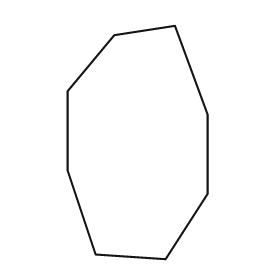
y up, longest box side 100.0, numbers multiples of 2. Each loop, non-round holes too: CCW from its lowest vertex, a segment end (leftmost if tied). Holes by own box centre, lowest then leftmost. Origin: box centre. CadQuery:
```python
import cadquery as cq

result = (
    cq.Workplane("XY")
    .moveTo(12.0, -50.0)
    .lineTo(30.0, -22.0)
    .lineTo(30.0, 12.0)
    .lineTo(16.0, 50.0)
    .lineTo(-10.0, 46.0)
    .lineTo(-30.0, 22.0)
    .lineTo(-30.0, -12.0)
    .lineTo(-18.0, -48.0)
    .close()
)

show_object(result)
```